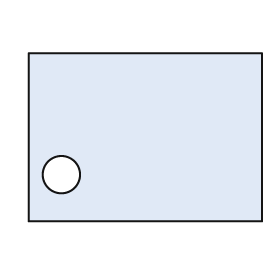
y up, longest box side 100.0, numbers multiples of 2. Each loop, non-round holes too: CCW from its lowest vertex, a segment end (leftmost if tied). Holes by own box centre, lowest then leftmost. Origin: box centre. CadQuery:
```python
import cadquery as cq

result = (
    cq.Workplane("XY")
    .moveTo(-50.0, -36.0)
    .lineTo(50.0, -36.0)
    .lineTo(50.0, 36.0)
    .lineTo(-50.0, 36.0)
    .close()
    .moveTo(-36.0, -16.0)
    .circle(8.0)
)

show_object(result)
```